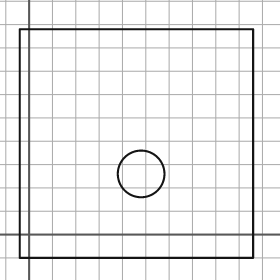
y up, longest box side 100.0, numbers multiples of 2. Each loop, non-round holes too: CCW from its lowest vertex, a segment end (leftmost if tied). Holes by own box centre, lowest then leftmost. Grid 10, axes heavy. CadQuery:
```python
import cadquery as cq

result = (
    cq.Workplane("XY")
    .moveTo(-4.0, -10.0)
    .lineTo(96.0, -10.0)
    .lineTo(96.0, 88.0)
    .lineTo(-4.0, 88.0)
    .close()
    .moveTo(48.0, 26.0)
    .circle(10.0)
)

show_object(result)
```